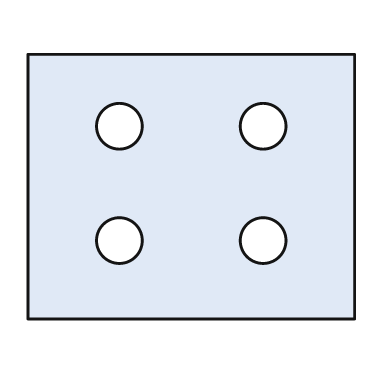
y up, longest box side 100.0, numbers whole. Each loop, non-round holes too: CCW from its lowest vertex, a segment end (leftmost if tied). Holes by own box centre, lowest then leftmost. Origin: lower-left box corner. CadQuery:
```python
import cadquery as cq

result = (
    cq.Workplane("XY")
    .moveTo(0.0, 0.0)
    .lineTo(100.0, 0.0)
    .lineTo(100.0, 81.0)
    .lineTo(0.0, 81.0)
    .close()
    .moveTo(28.0, 24.0)
    .circle(7.0)
    .moveTo(72.0, 24.0)
    .circle(7.0)
    .moveTo(28.0, 59.0)
    .circle(7.0)
    .moveTo(72.0, 59.0)
    .circle(7.0)
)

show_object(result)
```